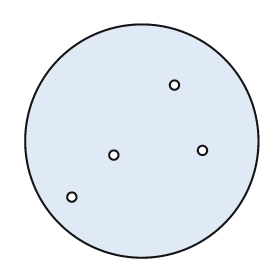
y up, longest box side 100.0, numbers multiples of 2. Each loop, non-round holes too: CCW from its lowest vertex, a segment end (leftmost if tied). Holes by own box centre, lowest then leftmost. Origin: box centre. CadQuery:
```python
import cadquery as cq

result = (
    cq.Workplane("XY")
    .moveTo(0.0, 0.0)
    .circle(50.0)
    .moveTo(-30.0, -24.0)
    .circle(2.0)
    .moveTo(-12.0, -6.0)
    .circle(2.0)
    .moveTo(26.0, -4.0)
    .circle(2.0)
    .moveTo(14.0, 24.0)
    .circle(2.0)
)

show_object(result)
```